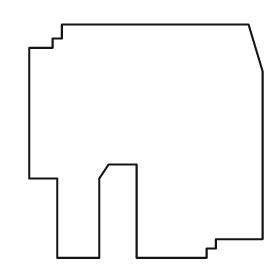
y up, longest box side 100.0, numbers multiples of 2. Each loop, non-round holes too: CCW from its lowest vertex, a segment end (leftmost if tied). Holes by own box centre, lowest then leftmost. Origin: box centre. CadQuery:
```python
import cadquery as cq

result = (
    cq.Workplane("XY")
    .moveTo(-38.0, -50.0)
    .lineTo(-20.0, -50.0)
    .lineTo(-20.0, -16.0)
    .lineTo(-16.0, -10.0)
    .lineTo(-4.0, -10.0)
    .lineTo(-4.0, -50.0)
    .lineTo(26.0, -50.0)
    .lineTo(26.0, -46.0)
    .lineTo(30.0, -46.0)
    .lineTo(30.0, -42.0)
    .lineTo(50.0, -42.0)
    .lineTo(50.0, 30.0)
    .lineTo(44.0, 50.0)
    .lineTo(-36.0, 50.0)
    .lineTo(-36.0, 44.0)
    .lineTo(-40.0, 44.0)
    .lineTo(-40.0, 40.0)
    .lineTo(-50.0, 40.0)
    .lineTo(-50.0, -16.0)
    .lineTo(-38.0, -16.0)
    .close()
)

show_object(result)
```